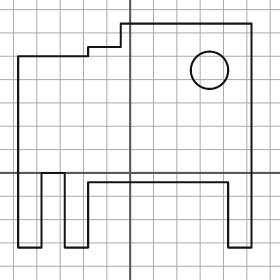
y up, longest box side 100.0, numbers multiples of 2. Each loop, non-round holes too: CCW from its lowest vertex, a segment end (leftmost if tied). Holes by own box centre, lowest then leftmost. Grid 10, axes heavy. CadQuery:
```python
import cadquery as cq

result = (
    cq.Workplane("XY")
    .moveTo(-48.0, -32.0)
    .lineTo(-38.0, -32.0)
    .lineTo(-38.0, 0.0)
    .lineTo(-28.0, 0.0)
    .lineTo(-28.0, -32.0)
    .lineTo(-18.0, -32.0)
    .lineTo(-18.0, -4.0)
    .lineTo(42.0, -4.0)
    .lineTo(42.0, -32.0)
    .lineTo(52.0, -32.0)
    .lineTo(52.0, 64.0)
    .lineTo(-4.0, 64.0)
    .lineTo(-4.0, 54.0)
    .lineTo(-18.0, 54.0)
    .lineTo(-18.0, 50.0)
    .lineTo(-48.0, 50.0)
    .close()
    .moveTo(34.0, 44.0)
    .circle(8.0)
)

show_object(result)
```